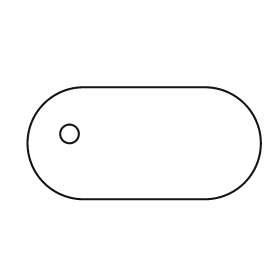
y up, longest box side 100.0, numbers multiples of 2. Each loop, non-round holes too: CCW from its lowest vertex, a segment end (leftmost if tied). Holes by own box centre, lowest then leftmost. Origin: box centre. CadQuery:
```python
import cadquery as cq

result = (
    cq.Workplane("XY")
    .moveTo(-26.0, -24.0)
    .lineTo(26.0, -24.0)
    .threePointArc((50.0, 0.0), (26.0, 24.0))
    .lineTo(-26.0, 24.0)
    .threePointArc((-50.0, 0.0), (-26.0, -24.0))
    .close()
    .moveTo(-32.0, 4.0)
    .circle(4.0)
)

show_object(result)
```